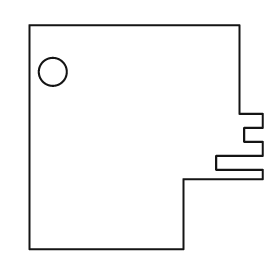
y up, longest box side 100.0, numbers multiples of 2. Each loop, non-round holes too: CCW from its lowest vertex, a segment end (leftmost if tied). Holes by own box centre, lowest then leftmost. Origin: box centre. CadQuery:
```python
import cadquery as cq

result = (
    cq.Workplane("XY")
    .moveTo(-50.0, -48.0)
    .lineTo(16.0, -48.0)
    .lineTo(16.0, -18.0)
    .lineTo(50.0, -18.0)
    .lineTo(50.0, -14.0)
    .lineTo(30.0, -14.0)
    .lineTo(30.0, -8.0)
    .lineTo(50.0, -8.0)
    .lineTo(50.0, -2.0)
    .lineTo(42.0, -2.0)
    .lineTo(42.0, 4.0)
    .lineTo(50.0, 4.0)
    .lineTo(50.0, 10.0)
    .lineTo(40.0, 10.0)
    .lineTo(40.0, 48.0)
    .lineTo(-50.0, 48.0)
    .close()
    .moveTo(-40.0, 28.0)
    .circle(6.0)
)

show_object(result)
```